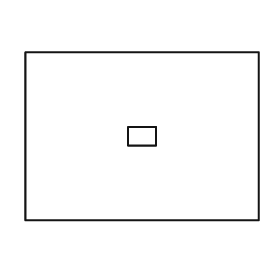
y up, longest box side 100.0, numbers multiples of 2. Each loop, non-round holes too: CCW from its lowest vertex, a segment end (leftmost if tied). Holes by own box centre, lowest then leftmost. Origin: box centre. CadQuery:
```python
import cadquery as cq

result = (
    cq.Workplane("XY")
    .moveTo(-50.0, -36.0)
    .lineTo(50.0, -36.0)
    .lineTo(50.0, 36.0)
    .lineTo(-50.0, 36.0)
    .close()
    .moveTo(-6.0, -4.0)
    .lineTo(6.0, -4.0)
    .lineTo(6.0, 4.0)
    .lineTo(-6.0, 4.0)
    .close()
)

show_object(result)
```